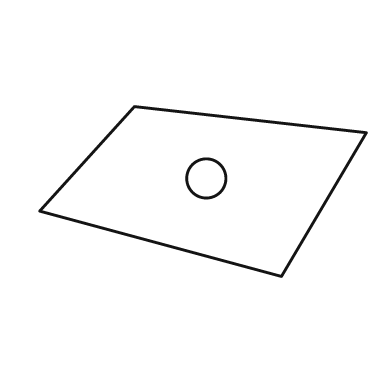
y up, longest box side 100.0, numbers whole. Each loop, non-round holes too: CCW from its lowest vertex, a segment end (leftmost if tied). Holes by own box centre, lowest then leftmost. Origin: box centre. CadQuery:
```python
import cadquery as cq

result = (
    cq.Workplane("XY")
    .moveTo(24.0, -26.0)
    .lineTo(50.0, 18.0)
    .lineTo(-21.0, 26.0)
    .lineTo(-50.0, -6.0)
    .close()
    .moveTo(1.0, 4.0)
    .circle(6.0)
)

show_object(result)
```